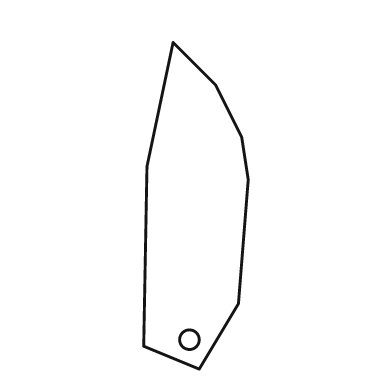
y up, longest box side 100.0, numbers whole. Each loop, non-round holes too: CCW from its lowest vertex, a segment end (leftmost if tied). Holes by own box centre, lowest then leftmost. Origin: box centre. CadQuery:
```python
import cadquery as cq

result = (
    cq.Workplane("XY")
    .moveTo(1.0, -50.0)
    .lineTo(13.0, -30.0)
    .lineTo(16.0, 8.0)
    .lineTo(14.0, 21.0)
    .lineTo(6.0, 37.0)
    .lineTo(-7.0, 50.0)
    .lineTo(-15.0, 12.0)
    .lineTo(-16.0, -43.0)
    .close()
    .moveTo(-2.0, -41.0)
    .circle(3.0)
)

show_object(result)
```